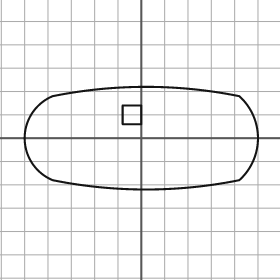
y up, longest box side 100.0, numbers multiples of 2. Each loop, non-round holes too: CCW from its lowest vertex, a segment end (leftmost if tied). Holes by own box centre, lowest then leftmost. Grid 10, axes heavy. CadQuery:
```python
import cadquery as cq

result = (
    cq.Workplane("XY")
    .moveTo(-38.0, -18.0)
    .threePointArc((2.0, -22.0), (42.0, -18.0))
    .threePointArc((50.0, 0.0), (42.0, 18.0))
    .threePointArc((2.0, 22.0), (-38.0, 18.0))
    .threePointArc((-50.0, 0.0), (-38.0, -18.0))
    .close()
    .moveTo(-8.0, 6.0)
    .lineTo(0.0, 6.0)
    .lineTo(0.0, 14.0)
    .lineTo(-8.0, 14.0)
    .close()
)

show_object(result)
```